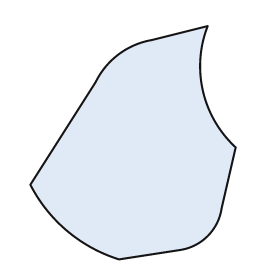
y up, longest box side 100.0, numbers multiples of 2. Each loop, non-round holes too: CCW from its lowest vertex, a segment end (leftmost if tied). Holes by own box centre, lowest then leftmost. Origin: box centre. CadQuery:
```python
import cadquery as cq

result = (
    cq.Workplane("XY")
    .moveTo(-6.0, -50.0)
    .lineTo(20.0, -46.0)
    .threePointArc((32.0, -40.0), (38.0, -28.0))
    .lineTo(44.0, -2.0)
    .threePointArc((30.0, 22.0), (32.0, 50.0))
    .lineTo(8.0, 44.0)
    .threePointArc((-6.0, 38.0), (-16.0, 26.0))
    .lineTo(-44.0, -18.0)
    .threePointArc((-28.0, -38.0), (-6.0, -50.0))
    .close()
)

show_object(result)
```